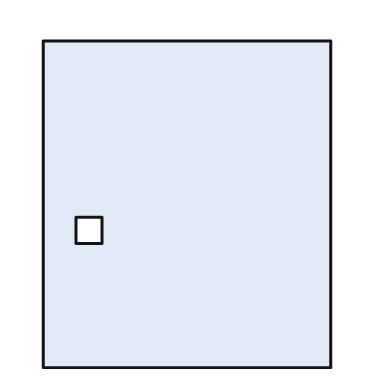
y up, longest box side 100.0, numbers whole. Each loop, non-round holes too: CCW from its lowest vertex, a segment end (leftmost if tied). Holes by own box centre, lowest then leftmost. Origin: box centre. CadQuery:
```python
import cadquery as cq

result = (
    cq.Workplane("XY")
    .moveTo(-44.0, -50.0)
    .lineTo(44.0, -50.0)
    .lineTo(44.0, 50.0)
    .lineTo(-44.0, 50.0)
    .close()
    .moveTo(-34.0, -12.0)
    .lineTo(-26.0, -12.0)
    .lineTo(-26.0, -4.0)
    .lineTo(-34.0, -4.0)
    .close()
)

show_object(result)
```